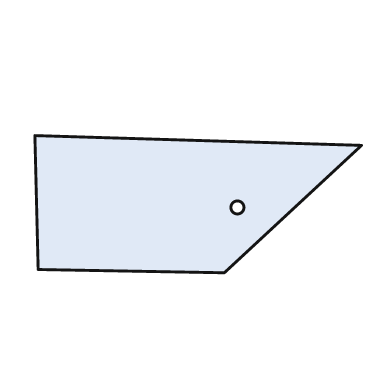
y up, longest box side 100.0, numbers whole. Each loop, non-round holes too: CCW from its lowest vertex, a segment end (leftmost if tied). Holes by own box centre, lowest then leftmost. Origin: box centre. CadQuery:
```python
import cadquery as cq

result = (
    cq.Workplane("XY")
    .moveTo(8.0, -21.0)
    .lineTo(50.0, 18.0)
    .lineTo(-50.0, 21.0)
    .lineTo(-49.0, -20.0)
    .close()
    .moveTo(12.0, -1.0)
    .circle(2.0)
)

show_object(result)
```